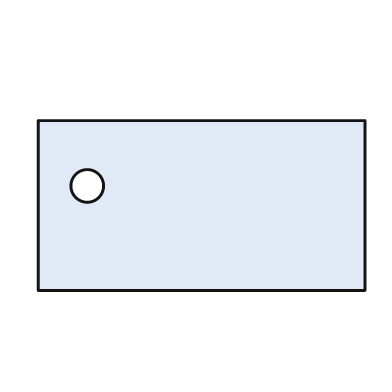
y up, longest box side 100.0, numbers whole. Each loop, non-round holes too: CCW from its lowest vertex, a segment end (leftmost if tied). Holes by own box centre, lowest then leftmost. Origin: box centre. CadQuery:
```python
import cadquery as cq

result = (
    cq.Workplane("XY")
    .moveTo(-50.0, -26.0)
    .lineTo(50.0, -26.0)
    .lineTo(50.0, 26.0)
    .lineTo(-50.0, 26.0)
    .close()
    .moveTo(-35.0, 6.0)
    .circle(5.0)
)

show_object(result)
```